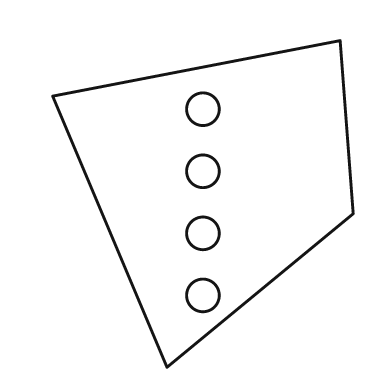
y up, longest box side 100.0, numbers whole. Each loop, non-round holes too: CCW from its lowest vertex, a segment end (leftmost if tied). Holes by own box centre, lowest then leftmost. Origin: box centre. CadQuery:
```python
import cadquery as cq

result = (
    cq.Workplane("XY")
    .moveTo(-11.0, -50.0)
    .lineTo(46.0, -3.0)
    .lineTo(42.0, 50.0)
    .lineTo(-46.0, 33.0)
    .close()
    .moveTo(0.0, -28.0)
    .circle(5.0)
    .moveTo(0.0, -9.0)
    .circle(5.0)
    .moveTo(0.0, 10.0)
    .circle(5.0)
    .moveTo(0.0, 29.0)
    .circle(5.0)
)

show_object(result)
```